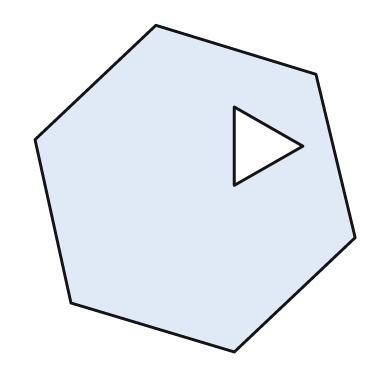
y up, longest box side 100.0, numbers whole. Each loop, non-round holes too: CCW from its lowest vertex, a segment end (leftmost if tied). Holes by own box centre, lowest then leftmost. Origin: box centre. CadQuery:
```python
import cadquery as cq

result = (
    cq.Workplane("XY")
    .moveTo(12.0, -50.0)
    .lineTo(49.0, -15.0)
    .lineTo(37.0, 35.0)
    .lineTo(-12.0, 50.0)
    .lineTo(-49.0, 15.0)
    .lineTo(-38.0, -35.0)
    .close()
    .moveTo(12.0, 1.0)
    .lineTo(33.0, 13.0)
    .lineTo(12.0, 25.0)
    .close()
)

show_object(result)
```